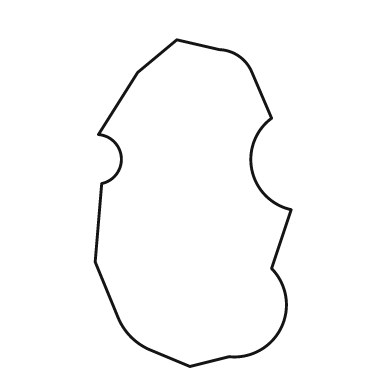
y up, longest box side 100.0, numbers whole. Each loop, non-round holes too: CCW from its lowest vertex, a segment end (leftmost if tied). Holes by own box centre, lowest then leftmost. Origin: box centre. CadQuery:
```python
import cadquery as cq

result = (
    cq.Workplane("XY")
    .moveTo(-1.0, -50.0)
    .lineTo(11.0, -47.0)
    .threePointArc((27.0, -38.0), (24.0, -20.0))
    .lineTo(30.0, -2.0)
    .threePointArc((18.0, 10.0), (24.0, 26.0))
    .lineTo(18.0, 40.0)
    .threePointArc((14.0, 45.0), (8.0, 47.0))
    .lineTo(-5.0, 50.0)
    .lineTo(-17.0, 40.0)
    .lineTo(-29.0, 21.0)
    .threePointArc((-22.0, 14.0), (-28.0, 6.0))
    .lineTo(-30.0, -18.0)
    .lineTo(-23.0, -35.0)
    .threePointArc((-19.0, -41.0), (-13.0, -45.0))
    .close()
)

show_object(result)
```